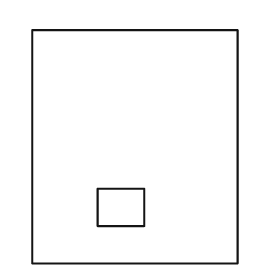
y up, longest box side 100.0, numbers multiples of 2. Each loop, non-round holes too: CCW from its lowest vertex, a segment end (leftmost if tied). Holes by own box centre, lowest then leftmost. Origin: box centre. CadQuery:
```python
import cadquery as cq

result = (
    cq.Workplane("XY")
    .moveTo(-44.0, -50.0)
    .lineTo(44.0, -50.0)
    .lineTo(44.0, 50.0)
    .lineTo(-44.0, 50.0)
    .close()
    .moveTo(-16.0, -34.0)
    .lineTo(4.0, -34.0)
    .lineTo(4.0, -18.0)
    .lineTo(-16.0, -18.0)
    .close()
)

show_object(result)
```